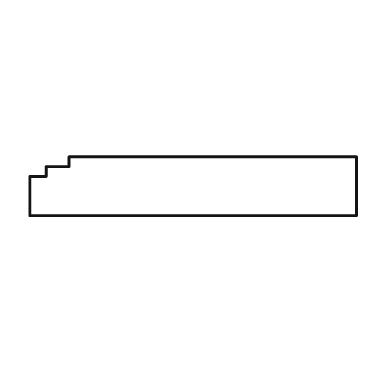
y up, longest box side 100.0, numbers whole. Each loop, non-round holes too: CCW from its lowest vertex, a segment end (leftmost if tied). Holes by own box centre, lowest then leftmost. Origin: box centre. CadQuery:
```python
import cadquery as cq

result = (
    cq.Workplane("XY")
    .moveTo(-50.0, -9.0)
    .lineTo(50.0, -9.0)
    .lineTo(50.0, 9.0)
    .lineTo(-38.0, 9.0)
    .lineTo(-38.0, 6.0)
    .lineTo(-45.0, 6.0)
    .lineTo(-45.0, 3.0)
    .lineTo(-50.0, 3.0)
    .close()
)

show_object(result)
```